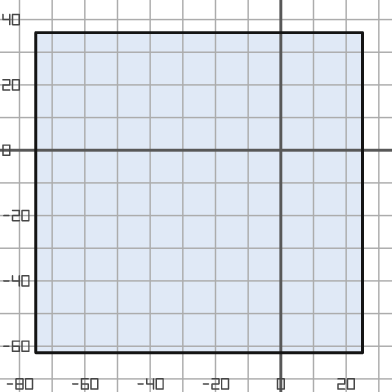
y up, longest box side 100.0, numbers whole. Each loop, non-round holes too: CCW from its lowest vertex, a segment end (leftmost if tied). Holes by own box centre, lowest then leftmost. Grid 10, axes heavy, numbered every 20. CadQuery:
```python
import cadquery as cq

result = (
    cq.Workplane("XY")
    .moveTo(-75.0, -62.0)
    .lineTo(25.0, -62.0)
    .lineTo(25.0, 36.0)
    .lineTo(-75.0, 36.0)
    .close()
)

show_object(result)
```